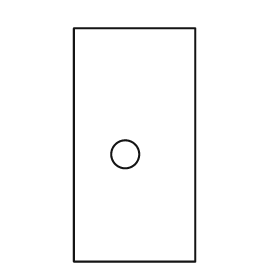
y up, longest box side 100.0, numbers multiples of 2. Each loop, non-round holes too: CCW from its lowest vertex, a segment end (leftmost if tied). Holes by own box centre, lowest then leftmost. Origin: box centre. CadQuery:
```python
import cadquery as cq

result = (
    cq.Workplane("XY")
    .moveTo(-26.0, -50.0)
    .lineTo(26.0, -50.0)
    .lineTo(26.0, 50.0)
    .lineTo(-26.0, 50.0)
    .close()
    .moveTo(-4.0, -4.0)
    .circle(6.0)
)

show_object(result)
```